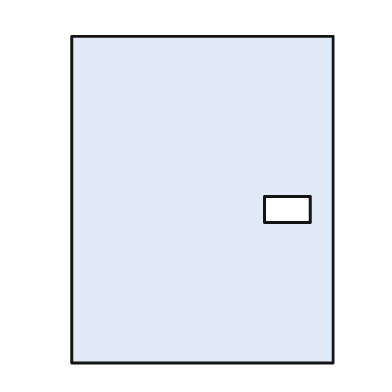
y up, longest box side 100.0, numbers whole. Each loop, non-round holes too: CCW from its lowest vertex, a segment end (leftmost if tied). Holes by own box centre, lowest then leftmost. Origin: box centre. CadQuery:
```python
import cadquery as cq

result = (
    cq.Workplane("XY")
    .moveTo(-40.0, -50.0)
    .lineTo(40.0, -50.0)
    .lineTo(40.0, 50.0)
    .lineTo(-40.0, 50.0)
    .close()
    .moveTo(19.0, -7.0)
    .lineTo(33.0, -7.0)
    .lineTo(33.0, 1.0)
    .lineTo(19.0, 1.0)
    .close()
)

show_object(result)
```